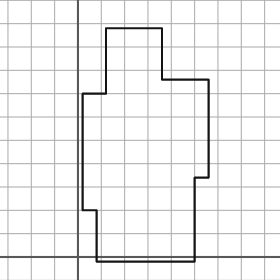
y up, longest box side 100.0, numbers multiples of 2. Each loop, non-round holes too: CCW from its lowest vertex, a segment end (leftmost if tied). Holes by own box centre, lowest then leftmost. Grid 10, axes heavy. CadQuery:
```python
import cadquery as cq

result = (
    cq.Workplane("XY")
    .moveTo(8.0, -2.0)
    .lineTo(50.0, -2.0)
    .lineTo(50.0, 34.0)
    .lineTo(56.0, 34.0)
    .lineTo(56.0, 76.0)
    .lineTo(36.0, 76.0)
    .lineTo(36.0, 98.0)
    .lineTo(12.0, 98.0)
    .lineTo(12.0, 70.0)
    .lineTo(2.0, 70.0)
    .lineTo(2.0, 20.0)
    .lineTo(8.0, 20.0)
    .close()
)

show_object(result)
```